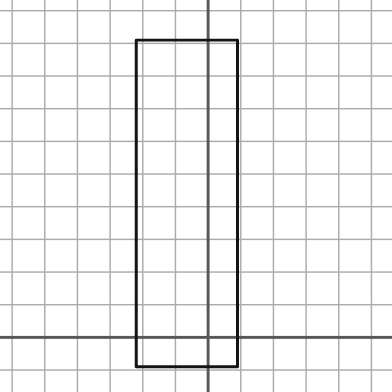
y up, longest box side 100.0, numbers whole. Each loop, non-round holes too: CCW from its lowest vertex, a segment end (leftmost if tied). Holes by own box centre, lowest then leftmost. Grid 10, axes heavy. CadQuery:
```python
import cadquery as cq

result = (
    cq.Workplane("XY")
    .moveTo(-22.0, -9.0)
    .lineTo(9.0, -9.0)
    .lineTo(9.0, 91.0)
    .lineTo(-22.0, 91.0)
    .close()
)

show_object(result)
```